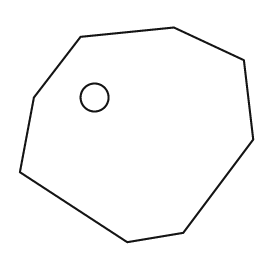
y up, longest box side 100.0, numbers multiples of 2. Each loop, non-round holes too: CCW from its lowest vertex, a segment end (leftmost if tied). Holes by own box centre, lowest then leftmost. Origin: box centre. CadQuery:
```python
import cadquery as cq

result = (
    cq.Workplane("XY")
    .moveTo(-4.0, -46.0)
    .lineTo(20.0, -42.0)
    .lineTo(50.0, -2.0)
    .lineTo(46.0, 32.0)
    .lineTo(16.0, 46.0)
    .lineTo(-24.0, 42.0)
    .lineTo(-44.0, 16.0)
    .lineTo(-50.0, -16.0)
    .close()
    .moveTo(-18.0, 16.0)
    .circle(6.0)
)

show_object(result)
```